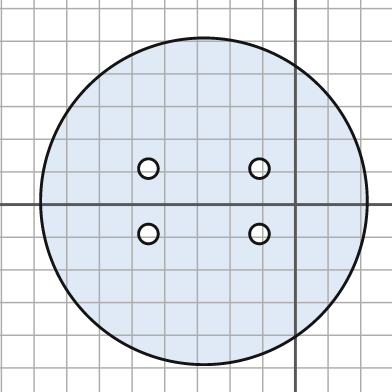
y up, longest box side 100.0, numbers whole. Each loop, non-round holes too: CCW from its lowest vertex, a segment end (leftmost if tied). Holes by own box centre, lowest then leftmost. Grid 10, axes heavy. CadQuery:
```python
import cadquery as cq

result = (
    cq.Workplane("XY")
    .moveTo(-28.0, 1.0)
    .circle(50.0)
    .moveTo(-45.0, -9.0)
    .circle(3.0)
    .moveTo(-11.0, -9.0)
    .circle(3.0)
    .moveTo(-45.0, 11.0)
    .circle(3.0)
    .moveTo(-11.0, 11.0)
    .circle(3.0)
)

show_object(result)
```